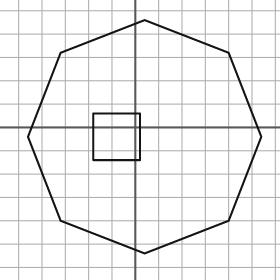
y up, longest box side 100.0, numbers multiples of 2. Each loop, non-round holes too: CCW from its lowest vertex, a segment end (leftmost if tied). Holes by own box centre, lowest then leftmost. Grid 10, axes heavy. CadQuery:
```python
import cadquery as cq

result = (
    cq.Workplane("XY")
    .moveTo(4.0, -54.0)
    .lineTo(40.0, -40.0)
    .lineTo(54.0, -4.0)
    .lineTo(40.0, 32.0)
    .lineTo(4.0, 46.0)
    .lineTo(-32.0, 32.0)
    .lineTo(-46.0, -4.0)
    .lineTo(-32.0, -40.0)
    .close()
    .moveTo(-18.0, -14.0)
    .lineTo(2.0, -14.0)
    .lineTo(2.0, 6.0)
    .lineTo(-18.0, 6.0)
    .close()
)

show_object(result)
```